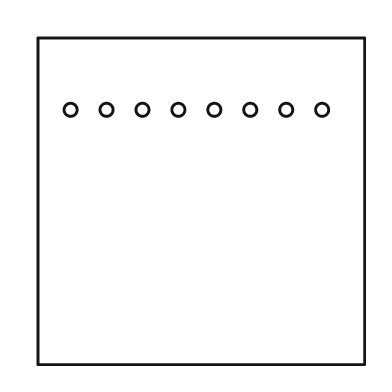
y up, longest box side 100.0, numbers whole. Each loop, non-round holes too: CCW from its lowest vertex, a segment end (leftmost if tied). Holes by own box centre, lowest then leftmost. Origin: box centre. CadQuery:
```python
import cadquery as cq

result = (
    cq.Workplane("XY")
    .moveTo(-50.0, -50.0)
    .lineTo(50.0, -50.0)
    .lineTo(50.0, 50.0)
    .lineTo(-50.0, 50.0)
    .close()
    .moveTo(-40.0, 28.0)
    .circle(2.0)
    .moveTo(-29.0, 28.0)
    .circle(2.0)
    .moveTo(-18.0, 28.0)
    .circle(2.0)
    .moveTo(-7.0, 28.0)
    .circle(2.0)
    .moveTo(4.0, 28.0)
    .circle(2.0)
    .moveTo(15.0, 28.0)
    .circle(2.0)
    .moveTo(26.0, 28.0)
    .circle(2.0)
    .moveTo(37.0, 28.0)
    .circle(2.0)
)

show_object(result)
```